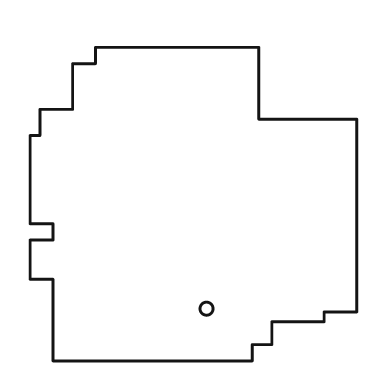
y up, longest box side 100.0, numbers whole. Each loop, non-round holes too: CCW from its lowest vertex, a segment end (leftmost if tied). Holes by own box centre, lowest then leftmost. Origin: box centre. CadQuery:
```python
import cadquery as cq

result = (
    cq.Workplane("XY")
    .moveTo(-43.0, -48.0)
    .lineTo(18.0, -48.0)
    .lineTo(18.0, -43.0)
    .lineTo(24.0, -43.0)
    .lineTo(24.0, -36.0)
    .lineTo(40.0, -36.0)
    .lineTo(40.0, -33.0)
    .lineTo(50.0, -33.0)
    .lineTo(50.0, 26.0)
    .lineTo(20.0, 26.0)
    .lineTo(20.0, 48.0)
    .lineTo(-30.0, 48.0)
    .lineTo(-30.0, 43.0)
    .lineTo(-37.0, 43.0)
    .lineTo(-37.0, 29.0)
    .lineTo(-47.0, 29.0)
    .lineTo(-47.0, 21.0)
    .lineTo(-50.0, 21.0)
    .lineTo(-50.0, -6.0)
    .lineTo(-43.0, -6.0)
    .lineTo(-43.0, -11.0)
    .lineTo(-50.0, -11.0)
    .lineTo(-50.0, -23.0)
    .lineTo(-43.0, -23.0)
    .close()
    .moveTo(4.0, -32.0)
    .circle(2.0)
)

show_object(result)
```